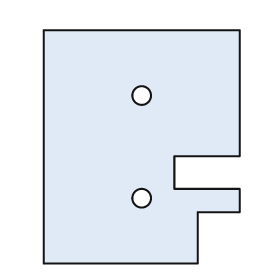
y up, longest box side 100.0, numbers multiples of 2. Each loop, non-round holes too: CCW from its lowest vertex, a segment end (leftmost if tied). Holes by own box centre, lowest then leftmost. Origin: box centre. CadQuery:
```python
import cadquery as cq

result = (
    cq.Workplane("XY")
    .moveTo(-42.0, -50.0)
    .lineTo(24.0, -50.0)
    .lineTo(24.0, -28.0)
    .lineTo(42.0, -28.0)
    .lineTo(42.0, -18.0)
    .lineTo(14.0, -18.0)
    .lineTo(14.0, -4.0)
    .lineTo(42.0, -4.0)
    .lineTo(42.0, 50.0)
    .lineTo(-42.0, 50.0)
    .close()
    .moveTo(0.0, -22.0)
    .circle(4.0)
    .moveTo(0.0, 22.0)
    .circle(4.0)
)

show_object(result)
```